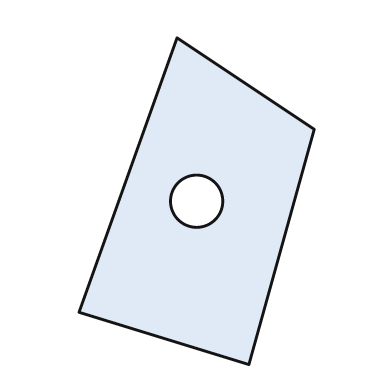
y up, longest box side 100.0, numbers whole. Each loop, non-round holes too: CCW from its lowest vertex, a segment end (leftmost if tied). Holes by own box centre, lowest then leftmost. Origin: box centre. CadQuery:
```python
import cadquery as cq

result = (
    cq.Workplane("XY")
    .moveTo(16.0, -50.0)
    .lineTo(36.0, 22.0)
    .lineTo(-6.0, 50.0)
    .lineTo(-36.0, -34.0)
    .close()
    .moveTo(0.0, 0.0)
    .circle(8.0)
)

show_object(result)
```